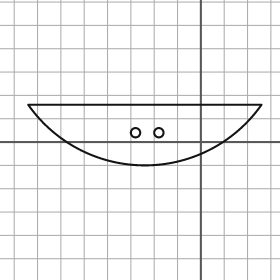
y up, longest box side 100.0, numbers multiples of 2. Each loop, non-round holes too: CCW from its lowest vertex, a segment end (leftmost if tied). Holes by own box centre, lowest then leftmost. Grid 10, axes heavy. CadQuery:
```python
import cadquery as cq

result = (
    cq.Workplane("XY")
    .moveTo(-74.0, 16.0)
    .threePointArc((-24.0, -10.0), (26.0, 16.0))
    .close()
    .moveTo(-28.0, 4.0)
    .circle(2.0)
    .moveTo(-18.0, 4.0)
    .circle(2.0)
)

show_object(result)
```